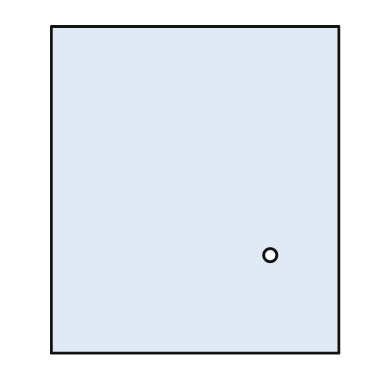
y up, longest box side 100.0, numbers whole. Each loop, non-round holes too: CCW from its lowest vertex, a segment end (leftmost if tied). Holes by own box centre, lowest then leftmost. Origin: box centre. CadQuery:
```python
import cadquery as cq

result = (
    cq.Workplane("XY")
    .moveTo(-44.0, -50.0)
    .lineTo(44.0, -50.0)
    .lineTo(44.0, 50.0)
    .lineTo(-44.0, 50.0)
    .close()
    .moveTo(23.0, -20.0)
    .circle(2.0)
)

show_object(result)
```